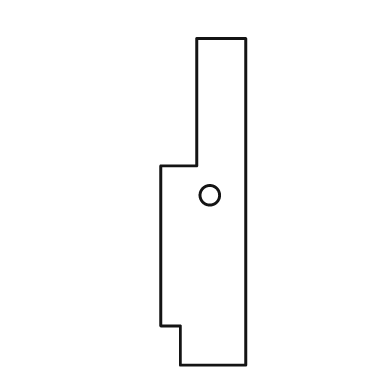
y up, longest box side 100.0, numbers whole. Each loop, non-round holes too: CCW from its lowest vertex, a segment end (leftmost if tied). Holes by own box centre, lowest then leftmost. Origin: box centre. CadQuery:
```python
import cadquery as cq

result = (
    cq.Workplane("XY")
    .moveTo(-7.0, -50.0)
    .lineTo(13.0, -50.0)
    .lineTo(13.0, 50.0)
    .lineTo(-2.0, 50.0)
    .lineTo(-2.0, 11.0)
    .lineTo(-13.0, 11.0)
    .lineTo(-13.0, -38.0)
    .lineTo(-7.0, -38.0)
    .close()
    .moveTo(2.0, 2.0)
    .circle(3.0)
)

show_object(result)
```